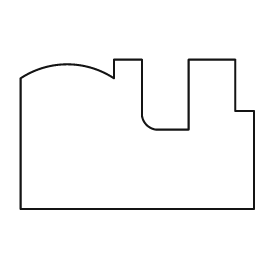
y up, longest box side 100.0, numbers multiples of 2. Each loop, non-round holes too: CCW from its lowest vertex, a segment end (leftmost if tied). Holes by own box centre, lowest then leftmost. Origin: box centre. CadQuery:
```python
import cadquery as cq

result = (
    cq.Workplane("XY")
    .moveTo(-50.0, -32.0)
    .lineTo(50.0, -32.0)
    .lineTo(50.0, 10.0)
    .lineTo(42.0, 10.0)
    .lineTo(42.0, 32.0)
    .lineTo(22.0, 32.0)
    .lineTo(22.0, 2.0)
    .lineTo(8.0, 2.0)
    .threePointArc((4.0, 4.0), (2.0, 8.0))
    .lineTo(2.0, 32.0)
    .lineTo(-10.0, 32.0)
    .lineTo(-10.0, 24.0)
    .threePointArc((-30.0, 30.0), (-50.0, 24.0))
    .close()
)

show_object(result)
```